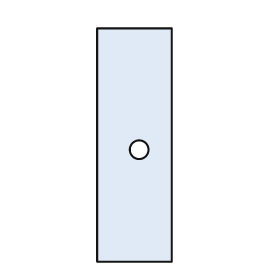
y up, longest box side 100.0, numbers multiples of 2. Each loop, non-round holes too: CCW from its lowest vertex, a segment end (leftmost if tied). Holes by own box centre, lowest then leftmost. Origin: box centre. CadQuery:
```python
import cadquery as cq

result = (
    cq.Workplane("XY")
    .moveTo(-16.0, -50.0)
    .lineTo(16.0, -50.0)
    .lineTo(16.0, 50.0)
    .lineTo(-16.0, 50.0)
    .close()
    .moveTo(2.0, -2.0)
    .circle(4.0)
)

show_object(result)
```